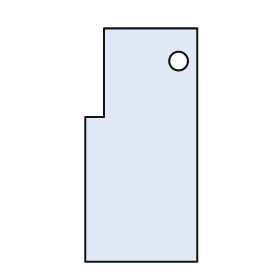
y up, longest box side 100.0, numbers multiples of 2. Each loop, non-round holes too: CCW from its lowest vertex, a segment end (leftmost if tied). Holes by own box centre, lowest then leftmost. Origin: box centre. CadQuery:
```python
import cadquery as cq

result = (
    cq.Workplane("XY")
    .moveTo(-24.0, -50.0)
    .lineTo(24.0, -50.0)
    .lineTo(24.0, 50.0)
    .lineTo(-16.0, 50.0)
    .lineTo(-16.0, 12.0)
    .lineTo(-24.0, 12.0)
    .close()
    .moveTo(16.0, 36.0)
    .circle(4.0)
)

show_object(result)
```